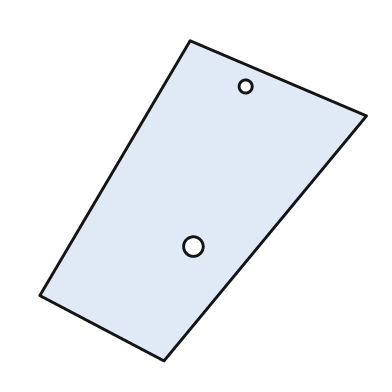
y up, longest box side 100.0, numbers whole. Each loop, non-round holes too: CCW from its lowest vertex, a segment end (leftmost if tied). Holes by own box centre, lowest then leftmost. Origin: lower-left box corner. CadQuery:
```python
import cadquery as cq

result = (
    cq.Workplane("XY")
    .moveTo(38.0, 0.0)
    .lineTo(100.0, 75.0)
    .lineTo(46.0, 98.0)
    .lineTo(0.0, 20.0)
    .close()
    .moveTo(47.0, 35.0)
    .circle(3.0)
    .moveTo(63.0, 84.0)
    .circle(2.0)
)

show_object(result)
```